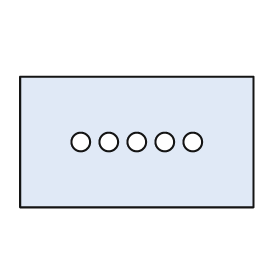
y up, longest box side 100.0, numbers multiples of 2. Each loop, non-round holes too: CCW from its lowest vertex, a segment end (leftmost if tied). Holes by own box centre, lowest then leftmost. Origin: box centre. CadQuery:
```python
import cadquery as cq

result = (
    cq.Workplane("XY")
    .moveTo(-50.0, -28.0)
    .lineTo(50.0, -28.0)
    .lineTo(50.0, 28.0)
    .lineTo(-50.0, 28.0)
    .close()
    .moveTo(-24.0, 0.0)
    .circle(4.0)
    .moveTo(-12.0, 0.0)
    .circle(4.0)
    .moveTo(0.0, 0.0)
    .circle(4.0)
    .moveTo(12.0, 0.0)
    .circle(4.0)
    .moveTo(24.0, 0.0)
    .circle(4.0)
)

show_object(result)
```